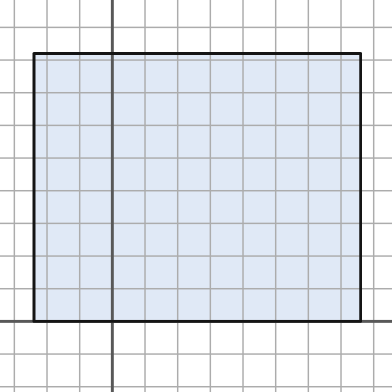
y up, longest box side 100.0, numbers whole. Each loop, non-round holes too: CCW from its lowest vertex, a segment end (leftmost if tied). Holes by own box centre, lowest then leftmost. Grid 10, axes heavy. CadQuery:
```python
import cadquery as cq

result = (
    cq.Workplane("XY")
    .moveTo(-24.0, 0.0)
    .lineTo(76.0, 0.0)
    .lineTo(76.0, 82.0)
    .lineTo(-24.0, 82.0)
    .close()
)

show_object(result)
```